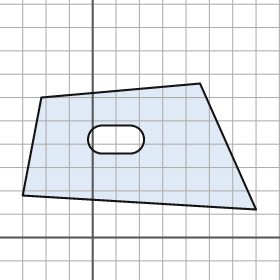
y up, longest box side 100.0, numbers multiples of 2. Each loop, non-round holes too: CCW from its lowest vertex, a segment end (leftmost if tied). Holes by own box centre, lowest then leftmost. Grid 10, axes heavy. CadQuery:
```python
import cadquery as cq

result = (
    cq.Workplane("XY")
    .moveTo(70.0, 12.0)
    .lineTo(46.0, 66.0)
    .lineTo(-22.0, 60.0)
    .lineTo(-30.0, 18.0)
    .close()
    .moveTo(4.0, 36.0)
    .lineTo(16.0, 36.0)
    .threePointArc((22.0, 42.0), (16.0, 48.0))
    .lineTo(4.0, 48.0)
    .threePointArc((-2.0, 42.0), (4.0, 36.0))
    .close()
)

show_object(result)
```